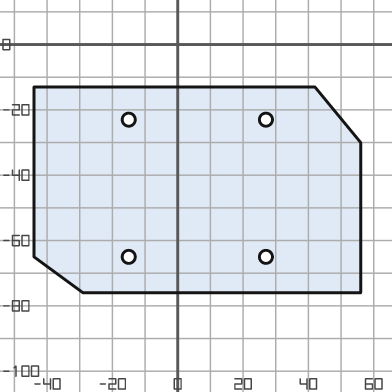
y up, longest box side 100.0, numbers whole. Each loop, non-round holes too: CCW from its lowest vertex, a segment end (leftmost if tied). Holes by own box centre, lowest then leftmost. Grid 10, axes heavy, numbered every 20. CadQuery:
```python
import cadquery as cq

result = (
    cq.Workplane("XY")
    .moveTo(-29.0, -76.0)
    .lineTo(56.0, -76.0)
    .lineTo(56.0, -30.0)
    .lineTo(42.0, -13.0)
    .lineTo(-44.0, -13.0)
    .lineTo(-44.0, -65.0)
    .close()
    .moveTo(-15.0, -65.0)
    .circle(2.0)
    .moveTo(27.0, -65.0)
    .circle(2.0)
    .moveTo(-15.0, -23.0)
    .circle(2.0)
    .moveTo(27.0, -23.0)
    .circle(2.0)
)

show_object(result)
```